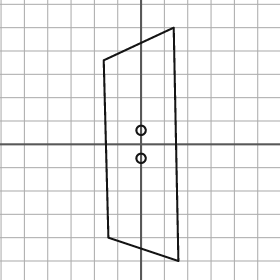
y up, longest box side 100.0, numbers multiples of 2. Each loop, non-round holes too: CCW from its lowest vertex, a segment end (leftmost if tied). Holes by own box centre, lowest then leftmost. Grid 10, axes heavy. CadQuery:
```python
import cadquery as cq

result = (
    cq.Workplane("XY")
    .moveTo(16.0, -50.0)
    .lineTo(14.0, 50.0)
    .lineTo(-16.0, 36.0)
    .lineTo(-14.0, -40.0)
    .close()
    .moveTo(0.0, -6.0)
    .circle(2.0)
    .moveTo(0.0, 6.0)
    .circle(2.0)
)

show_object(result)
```